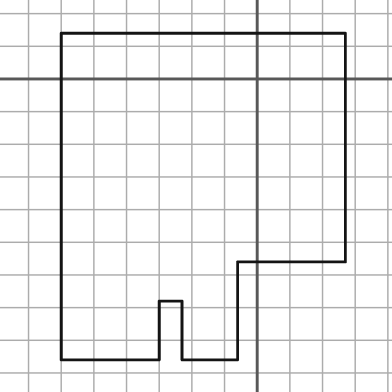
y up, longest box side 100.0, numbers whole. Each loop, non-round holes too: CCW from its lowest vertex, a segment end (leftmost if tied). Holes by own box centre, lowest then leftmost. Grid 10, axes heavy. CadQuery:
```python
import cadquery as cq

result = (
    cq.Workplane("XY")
    .moveTo(-60.0, -86.0)
    .lineTo(-30.0, -86.0)
    .lineTo(-30.0, -68.0)
    .lineTo(-23.0, -68.0)
    .lineTo(-23.0, -86.0)
    .lineTo(-6.0, -86.0)
    .lineTo(-6.0, -56.0)
    .lineTo(27.0, -56.0)
    .lineTo(27.0, 14.0)
    .lineTo(-60.0, 14.0)
    .close()
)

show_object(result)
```